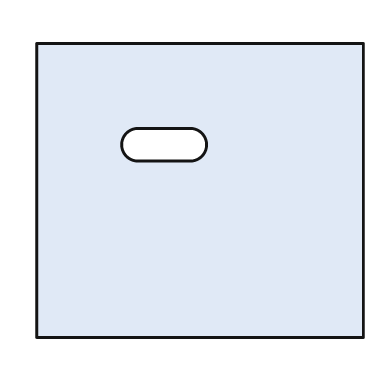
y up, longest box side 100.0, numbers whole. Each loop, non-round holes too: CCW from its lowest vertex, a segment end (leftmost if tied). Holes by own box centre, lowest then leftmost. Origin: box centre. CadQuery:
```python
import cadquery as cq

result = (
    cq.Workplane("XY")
    .moveTo(-50.0, -45.0)
    .lineTo(50.0, -45.0)
    .lineTo(50.0, 45.0)
    .lineTo(-50.0, 45.0)
    .close()
    .moveTo(-19.0, 9.0)
    .lineTo(-3.0, 9.0)
    .threePointArc((2.0, 14.0), (-3.0, 19.0))
    .lineTo(-19.0, 19.0)
    .threePointArc((-24.0, 14.0), (-19.0, 9.0))
    .close()
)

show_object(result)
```